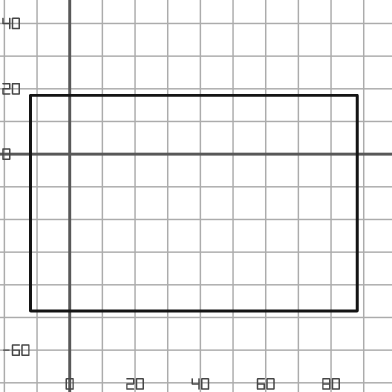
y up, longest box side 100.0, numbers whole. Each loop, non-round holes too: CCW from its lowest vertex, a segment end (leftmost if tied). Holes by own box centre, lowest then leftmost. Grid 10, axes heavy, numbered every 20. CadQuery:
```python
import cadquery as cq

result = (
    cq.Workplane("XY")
    .moveTo(-12.0, -48.0)
    .lineTo(88.0, -48.0)
    .lineTo(88.0, 18.0)
    .lineTo(-12.0, 18.0)
    .close()
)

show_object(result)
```